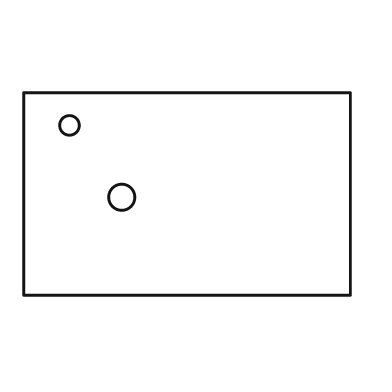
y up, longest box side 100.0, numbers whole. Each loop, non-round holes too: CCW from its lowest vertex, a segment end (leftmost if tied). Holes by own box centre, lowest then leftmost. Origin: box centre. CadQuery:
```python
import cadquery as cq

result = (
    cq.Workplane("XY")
    .moveTo(-50.0, -31.0)
    .lineTo(50.0, -31.0)
    .lineTo(50.0, 31.0)
    .lineTo(-50.0, 31.0)
    .close()
    .moveTo(-20.0, -1.0)
    .circle(4.0)
    .moveTo(-36.0, 21.0)
    .circle(3.0)
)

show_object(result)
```